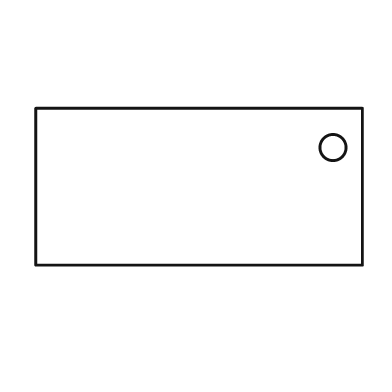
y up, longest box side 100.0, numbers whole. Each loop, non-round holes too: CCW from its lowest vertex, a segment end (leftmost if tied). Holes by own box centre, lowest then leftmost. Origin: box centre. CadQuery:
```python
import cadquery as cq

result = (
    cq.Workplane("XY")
    .moveTo(-50.0, -24.0)
    .lineTo(50.0, -24.0)
    .lineTo(50.0, 24.0)
    .lineTo(-50.0, 24.0)
    .close()
    .moveTo(41.0, 12.0)
    .circle(4.0)
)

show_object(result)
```